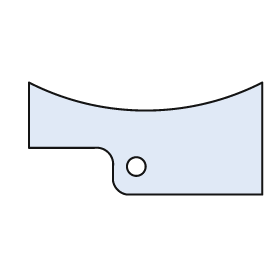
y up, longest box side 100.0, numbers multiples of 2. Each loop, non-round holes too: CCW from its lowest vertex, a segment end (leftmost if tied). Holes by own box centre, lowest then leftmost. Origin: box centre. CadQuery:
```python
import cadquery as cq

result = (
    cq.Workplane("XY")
    .moveTo(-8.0, -24.0)
    .lineTo(50.0, -24.0)
    .lineTo(50.0, 24.0)
    .threePointArc((0.0, 12.0), (-50.0, 24.0))
    .lineTo(-50.0, -4.0)
    .lineTo(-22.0, -4.0)
    .threePointArc((-16.0, -6.0), (-14.0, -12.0))
    .lineTo(-14.0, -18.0)
    .threePointArc((-12.0, -22.0), (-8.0, -24.0))
    .close()
    .moveTo(-4.0, -12.0)
    .circle(4.0)
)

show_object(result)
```